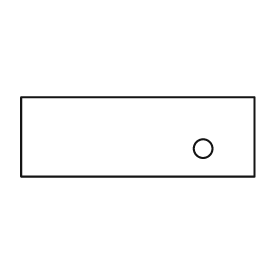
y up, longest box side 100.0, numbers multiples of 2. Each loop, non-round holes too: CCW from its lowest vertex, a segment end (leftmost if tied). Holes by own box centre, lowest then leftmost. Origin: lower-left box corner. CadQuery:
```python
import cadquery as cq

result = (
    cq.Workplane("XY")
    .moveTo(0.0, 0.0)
    .lineTo(100.0, 0.0)
    .lineTo(100.0, 34.0)
    .lineTo(0.0, 34.0)
    .close()
    .moveTo(78.0, 12.0)
    .circle(4.0)
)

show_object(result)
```